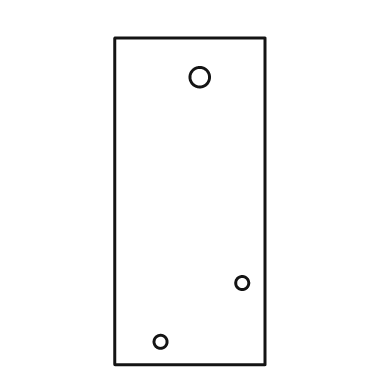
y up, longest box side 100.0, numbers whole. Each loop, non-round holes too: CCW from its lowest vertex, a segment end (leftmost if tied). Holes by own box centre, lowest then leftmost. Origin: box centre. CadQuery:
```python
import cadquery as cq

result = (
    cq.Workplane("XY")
    .moveTo(-23.0, -50.0)
    .lineTo(23.0, -50.0)
    .lineTo(23.0, 50.0)
    .lineTo(-23.0, 50.0)
    .close()
    .moveTo(-9.0, -43.0)
    .circle(2.0)
    .moveTo(16.0, -25.0)
    .circle(2.0)
    .moveTo(3.0, 38.0)
    .circle(3.0)
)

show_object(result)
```